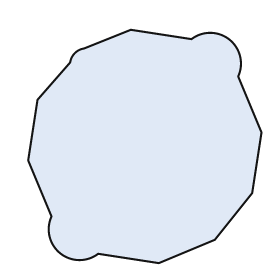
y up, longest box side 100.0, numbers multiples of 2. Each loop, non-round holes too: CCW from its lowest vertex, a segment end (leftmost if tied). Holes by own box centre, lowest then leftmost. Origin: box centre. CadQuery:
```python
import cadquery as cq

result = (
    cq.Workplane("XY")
    .moveTo(6.0, -50.0)
    .lineTo(30.0, -40.0)
    .lineTo(46.0, -20.0)
    .lineTo(50.0, 6.0)
    .lineTo(40.0, 30.0)
    .threePointArc((36.0, 46.0), (20.0, 46.0))
    .lineTo(-6.0, 50.0)
    .lineTo(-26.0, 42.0)
    .threePointArc((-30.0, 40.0), (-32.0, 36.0))
    .lineTo(-46.0, 20.0)
    .lineTo(-50.0, -6.0)
    .lineTo(-40.0, -30.0)
    .threePointArc((-36.0, -46.0), (-20.0, -46.0))
    .close()
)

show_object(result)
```